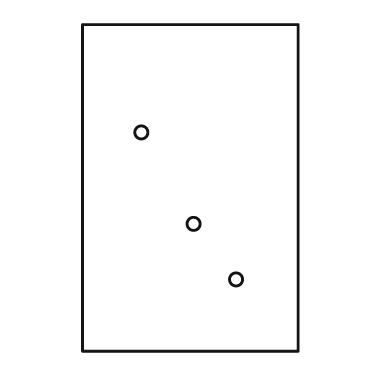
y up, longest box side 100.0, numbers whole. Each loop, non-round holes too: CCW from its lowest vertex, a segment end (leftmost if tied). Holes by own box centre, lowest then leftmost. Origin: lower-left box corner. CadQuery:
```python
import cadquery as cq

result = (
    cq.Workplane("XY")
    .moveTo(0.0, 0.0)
    .lineTo(66.0, 0.0)
    .lineTo(66.0, 100.0)
    .lineTo(0.0, 100.0)
    .close()
    .moveTo(47.0, 22.0)
    .circle(2.0)
    .moveTo(34.0, 39.0)
    .circle(2.0)
    .moveTo(18.0, 67.0)
    .circle(2.0)
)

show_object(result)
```